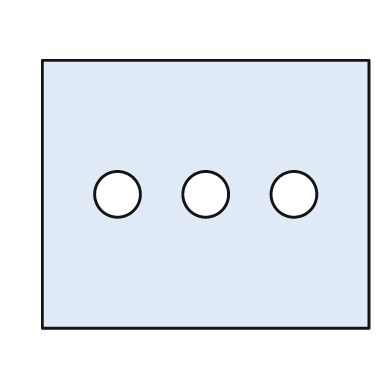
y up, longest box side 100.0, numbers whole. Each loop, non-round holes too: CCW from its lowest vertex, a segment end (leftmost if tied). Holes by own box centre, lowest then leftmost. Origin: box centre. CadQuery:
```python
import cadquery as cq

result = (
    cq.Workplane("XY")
    .moveTo(-50.0, -41.0)
    .lineTo(50.0, -41.0)
    .lineTo(50.0, 41.0)
    .lineTo(-50.0, 41.0)
    .close()
    .moveTo(-27.0, 0.0)
    .circle(7.0)
    .moveTo(0.0, 0.0)
    .circle(7.0)
    .moveTo(27.0, 0.0)
    .circle(7.0)
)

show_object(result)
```